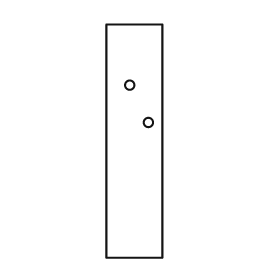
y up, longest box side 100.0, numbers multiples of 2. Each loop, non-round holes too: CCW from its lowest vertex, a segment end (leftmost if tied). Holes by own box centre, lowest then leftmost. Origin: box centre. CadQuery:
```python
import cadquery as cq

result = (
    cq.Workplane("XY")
    .moveTo(-12.0, -50.0)
    .lineTo(12.0, -50.0)
    .lineTo(12.0, 50.0)
    .lineTo(-12.0, 50.0)
    .close()
    .moveTo(6.0, 8.0)
    .circle(2.0)
    .moveTo(-2.0, 24.0)
    .circle(2.0)
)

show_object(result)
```